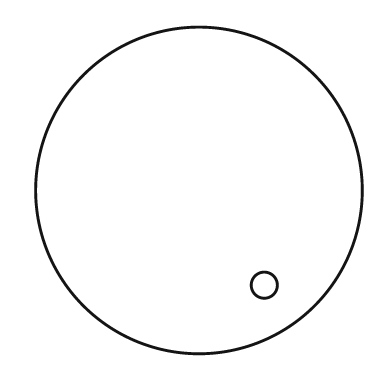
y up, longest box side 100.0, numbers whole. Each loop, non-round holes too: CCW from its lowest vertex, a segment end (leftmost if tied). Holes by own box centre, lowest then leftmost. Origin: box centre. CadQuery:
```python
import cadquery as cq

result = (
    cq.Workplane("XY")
    .moveTo(0.0, 0.0)
    .circle(50.0)
    .moveTo(20.0, -29.0)
    .circle(4.0)
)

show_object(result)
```